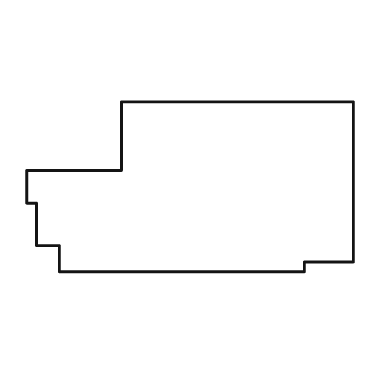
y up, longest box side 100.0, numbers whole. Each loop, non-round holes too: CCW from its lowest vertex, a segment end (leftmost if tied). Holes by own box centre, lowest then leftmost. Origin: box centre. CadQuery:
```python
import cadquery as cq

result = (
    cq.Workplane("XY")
    .moveTo(-40.0, -26.0)
    .lineTo(35.0, -26.0)
    .lineTo(35.0, -23.0)
    .lineTo(50.0, -23.0)
    .lineTo(50.0, 26.0)
    .lineTo(-21.0, 26.0)
    .lineTo(-21.0, 5.0)
    .lineTo(-50.0, 5.0)
    .lineTo(-50.0, -5.0)
    .lineTo(-47.0, -5.0)
    .lineTo(-47.0, -18.0)
    .lineTo(-40.0, -18.0)
    .close()
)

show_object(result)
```